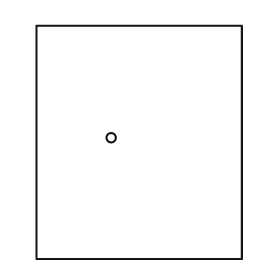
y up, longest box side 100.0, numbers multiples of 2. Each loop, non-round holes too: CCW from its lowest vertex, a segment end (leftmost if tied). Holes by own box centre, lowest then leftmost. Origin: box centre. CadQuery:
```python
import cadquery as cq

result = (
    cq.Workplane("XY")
    .moveTo(-44.0, -50.0)
    .lineTo(44.0, -50.0)
    .lineTo(44.0, 50.0)
    .lineTo(-44.0, 50.0)
    .close()
    .moveTo(-12.0, 2.0)
    .circle(2.0)
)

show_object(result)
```